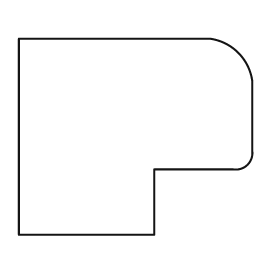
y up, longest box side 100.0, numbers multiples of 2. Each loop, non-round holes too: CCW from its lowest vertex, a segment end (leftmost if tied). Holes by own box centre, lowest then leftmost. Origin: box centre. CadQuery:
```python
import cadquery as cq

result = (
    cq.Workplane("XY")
    .moveTo(-50.0, -42.0)
    .lineTo(8.0, -42.0)
    .lineTo(8.0, -14.0)
    .lineTo(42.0, -14.0)
    .threePointArc((48.0, -12.0), (50.0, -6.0))
    .lineTo(50.0, 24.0)
    .threePointArc((44.0, 36.0), (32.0, 42.0))
    .lineTo(-50.0, 42.0)
    .close()
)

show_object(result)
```